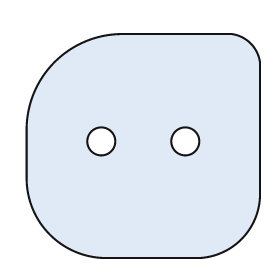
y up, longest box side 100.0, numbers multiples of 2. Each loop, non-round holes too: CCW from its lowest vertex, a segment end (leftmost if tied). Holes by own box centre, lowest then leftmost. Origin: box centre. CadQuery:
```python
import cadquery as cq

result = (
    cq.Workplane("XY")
    .moveTo(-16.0, -48.0)
    .lineTo(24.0, -48.0)
    .threePointArc((42.0, -40.0), (50.0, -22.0))
    .lineTo(50.0, 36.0)
    .threePointArc((46.0, 44.0), (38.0, 48.0))
    .lineTo(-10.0, 48.0)
    .threePointArc((-38.0, 36.0), (-50.0, 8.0))
    .lineTo(-50.0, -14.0)
    .threePointArc((-40.0, -38.0), (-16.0, -48.0))
    .close()
    .moveTo(-18.0, 2.0)
    .circle(6.0)
    .moveTo(18.0, 2.0)
    .circle(6.0)
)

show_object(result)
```